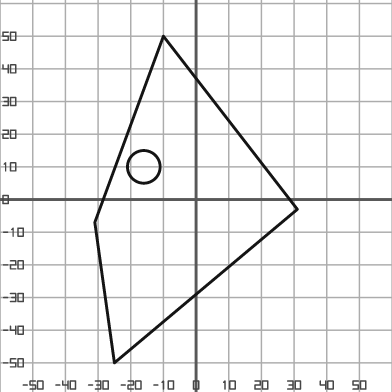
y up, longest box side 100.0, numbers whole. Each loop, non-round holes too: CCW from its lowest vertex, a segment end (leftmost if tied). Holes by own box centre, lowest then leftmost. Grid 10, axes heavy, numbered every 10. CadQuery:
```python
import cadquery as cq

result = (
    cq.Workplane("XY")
    .moveTo(-25.0, -50.0)
    .lineTo(31.0, -3.0)
    .lineTo(-10.0, 50.0)
    .lineTo(-31.0, -7.0)
    .close()
    .moveTo(-16.0, 10.0)
    .circle(5.0)
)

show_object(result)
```